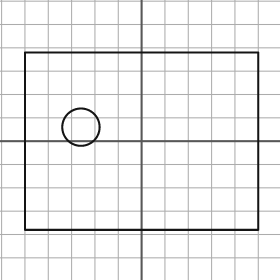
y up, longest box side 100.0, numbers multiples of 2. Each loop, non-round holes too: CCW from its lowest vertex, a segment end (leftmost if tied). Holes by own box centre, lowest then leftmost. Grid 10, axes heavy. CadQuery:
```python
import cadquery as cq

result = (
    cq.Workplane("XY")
    .moveTo(-50.0, -38.0)
    .lineTo(50.0, -38.0)
    .lineTo(50.0, 38.0)
    .lineTo(-50.0, 38.0)
    .close()
    .moveTo(-26.0, 6.0)
    .circle(8.0)
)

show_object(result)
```